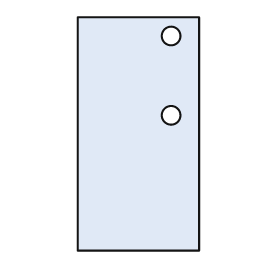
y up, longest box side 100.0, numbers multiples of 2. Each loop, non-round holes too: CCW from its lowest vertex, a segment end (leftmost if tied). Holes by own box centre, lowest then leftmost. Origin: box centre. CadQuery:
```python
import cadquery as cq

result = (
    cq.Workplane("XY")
    .moveTo(-26.0, -50.0)
    .lineTo(26.0, -50.0)
    .lineTo(26.0, 50.0)
    .lineTo(-26.0, 50.0)
    .close()
    .moveTo(14.0, 8.0)
    .circle(4.0)
    .moveTo(14.0, 42.0)
    .circle(4.0)
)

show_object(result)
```